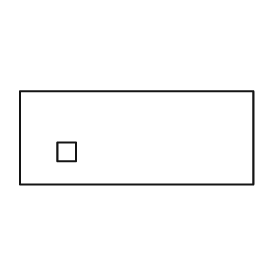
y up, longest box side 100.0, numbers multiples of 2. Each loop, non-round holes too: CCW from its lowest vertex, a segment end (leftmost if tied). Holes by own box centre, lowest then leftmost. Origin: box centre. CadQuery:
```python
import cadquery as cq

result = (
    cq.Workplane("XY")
    .moveTo(-50.0, -20.0)
    .lineTo(50.0, -20.0)
    .lineTo(50.0, 20.0)
    .lineTo(-50.0, 20.0)
    .close()
    .moveTo(-34.0, -10.0)
    .lineTo(-26.0, -10.0)
    .lineTo(-26.0, -2.0)
    .lineTo(-34.0, -2.0)
    .close()
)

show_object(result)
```